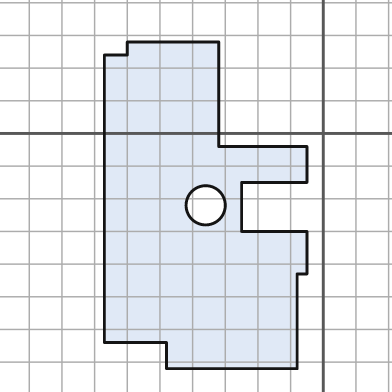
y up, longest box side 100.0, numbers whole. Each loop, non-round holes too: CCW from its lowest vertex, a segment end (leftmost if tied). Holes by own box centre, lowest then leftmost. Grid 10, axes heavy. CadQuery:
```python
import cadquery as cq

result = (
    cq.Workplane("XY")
    .moveTo(-48.0, -72.0)
    .lineTo(-8.0, -72.0)
    .lineTo(-8.0, -43.0)
    .lineTo(-5.0, -43.0)
    .lineTo(-5.0, -30.0)
    .lineTo(-25.0, -30.0)
    .lineTo(-25.0, -15.0)
    .lineTo(-5.0, -15.0)
    .lineTo(-5.0, -4.0)
    .lineTo(-32.0, -4.0)
    .lineTo(-32.0, 28.0)
    .lineTo(-60.0, 28.0)
    .lineTo(-60.0, 24.0)
    .lineTo(-67.0, 24.0)
    .lineTo(-67.0, -64.0)
    .lineTo(-48.0, -64.0)
    .close()
    .moveTo(-36.0, -22.0)
    .circle(6.0)
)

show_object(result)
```